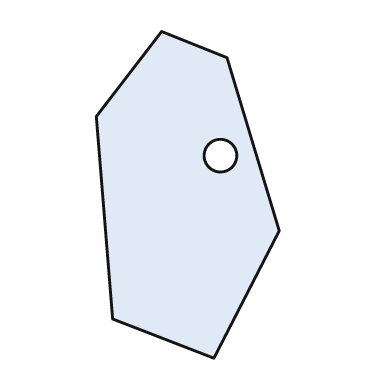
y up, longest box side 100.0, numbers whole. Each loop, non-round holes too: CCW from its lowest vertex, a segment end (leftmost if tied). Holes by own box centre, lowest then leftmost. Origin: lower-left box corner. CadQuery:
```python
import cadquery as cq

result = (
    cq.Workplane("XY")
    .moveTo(36.0, 0.0)
    .lineTo(56.0, 39.0)
    .lineTo(40.0, 92.0)
    .lineTo(20.0, 100.0)
    .lineTo(0.0, 74.0)
    .lineTo(5.0, 12.0)
    .close()
    .moveTo(38.0, 62.0)
    .circle(5.0)
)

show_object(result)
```